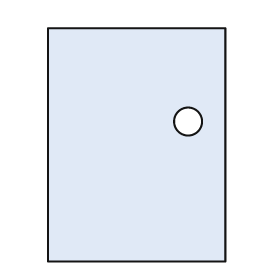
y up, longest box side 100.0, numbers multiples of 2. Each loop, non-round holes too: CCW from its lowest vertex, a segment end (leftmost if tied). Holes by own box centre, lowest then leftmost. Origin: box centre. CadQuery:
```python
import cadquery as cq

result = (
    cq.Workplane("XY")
    .moveTo(-38.0, -50.0)
    .lineTo(38.0, -50.0)
    .lineTo(38.0, 50.0)
    .lineTo(-38.0, 50.0)
    .close()
    .moveTo(22.0, 10.0)
    .circle(6.0)
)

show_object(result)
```